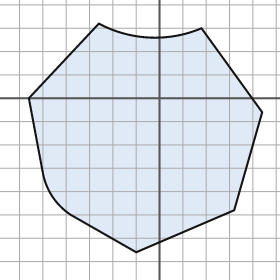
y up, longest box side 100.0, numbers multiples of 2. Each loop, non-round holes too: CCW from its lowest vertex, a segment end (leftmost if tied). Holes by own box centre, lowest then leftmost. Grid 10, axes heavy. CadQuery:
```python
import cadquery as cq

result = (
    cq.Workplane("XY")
    .moveTo(-10.0, -66.0)
    .lineTo(32.0, -48.0)
    .lineTo(44.0, -6.0)
    .lineTo(18.0, 30.0)
    .threePointArc((-4.0, 26.0), (-26.0, 32.0))
    .lineTo(-56.0, 0.0)
    .lineTo(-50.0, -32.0)
    .threePointArc((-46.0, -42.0), (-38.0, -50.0))
    .close()
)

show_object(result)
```